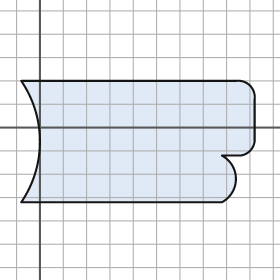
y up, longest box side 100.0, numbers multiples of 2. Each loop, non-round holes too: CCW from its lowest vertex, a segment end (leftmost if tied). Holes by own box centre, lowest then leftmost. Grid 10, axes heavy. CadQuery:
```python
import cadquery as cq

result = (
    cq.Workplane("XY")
    .moveTo(-8.0, -32.0)
    .lineTo(78.0, -32.0)
    .threePointArc((84.0, -22.0), (78.0, -12.0))
    .lineTo(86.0, -12.0)
    .threePointArc((90.0, -10.0), (92.0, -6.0))
    .lineTo(92.0, 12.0)
    .threePointArc((90.0, 18.0), (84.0, 20.0))
    .lineTo(-8.0, 20.0)
    .threePointArc((0.0, -6.0), (-8.0, -32.0))
    .close()
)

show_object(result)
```